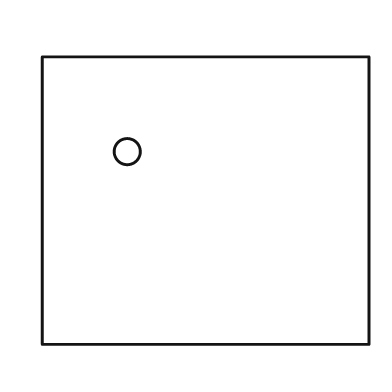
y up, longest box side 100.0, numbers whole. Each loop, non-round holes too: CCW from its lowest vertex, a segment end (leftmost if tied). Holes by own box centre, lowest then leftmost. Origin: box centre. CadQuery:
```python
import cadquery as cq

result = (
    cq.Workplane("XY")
    .moveTo(-50.0, -44.0)
    .lineTo(50.0, -44.0)
    .lineTo(50.0, 44.0)
    .lineTo(-50.0, 44.0)
    .close()
    .moveTo(-24.0, 15.0)
    .circle(4.0)
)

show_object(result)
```